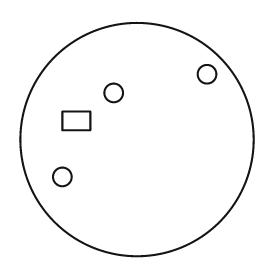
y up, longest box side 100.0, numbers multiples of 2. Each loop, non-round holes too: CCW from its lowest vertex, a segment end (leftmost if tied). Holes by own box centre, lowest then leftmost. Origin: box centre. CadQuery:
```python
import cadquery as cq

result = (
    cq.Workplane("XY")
    .moveTo(0.0, 0.0)
    .circle(50.0)
    .moveTo(-32.0, -16.0)
    .circle(4.0)
    .moveTo(-32.0, 4.0)
    .lineTo(-20.0, 4.0)
    .lineTo(-20.0, 12.0)
    .lineTo(-32.0, 12.0)
    .close()
    .moveTo(-10.0, 20.0)
    .circle(4.0)
    .moveTo(30.0, 28.0)
    .circle(4.0)
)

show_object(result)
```